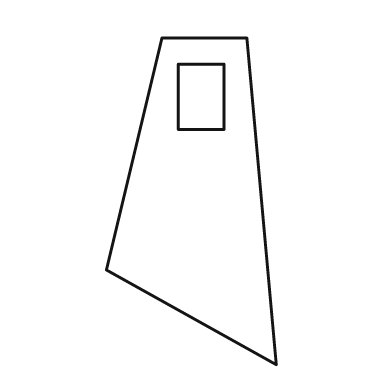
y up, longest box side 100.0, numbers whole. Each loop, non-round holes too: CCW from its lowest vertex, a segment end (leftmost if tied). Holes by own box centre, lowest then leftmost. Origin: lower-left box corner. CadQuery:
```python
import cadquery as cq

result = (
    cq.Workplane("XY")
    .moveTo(52.0, 0.0)
    .lineTo(43.0, 100.0)
    .lineTo(17.0, 100.0)
    .lineTo(0.0, 29.0)
    .close()
    .moveTo(22.0, 72.0)
    .lineTo(36.0, 72.0)
    .lineTo(36.0, 92.0)
    .lineTo(22.0, 92.0)
    .close()
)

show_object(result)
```